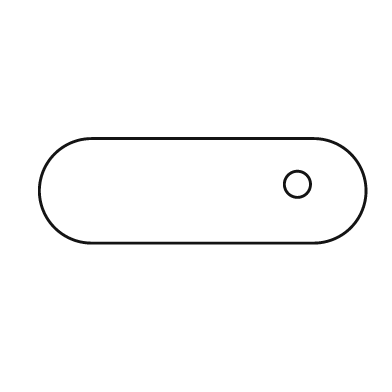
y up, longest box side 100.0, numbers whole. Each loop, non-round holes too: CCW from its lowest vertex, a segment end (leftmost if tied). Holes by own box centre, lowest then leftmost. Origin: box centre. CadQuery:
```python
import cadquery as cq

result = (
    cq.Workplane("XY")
    .moveTo(-34.0, -16.0)
    .lineTo(34.0, -16.0)
    .threePointArc((50.0, 0.0), (34.0, 16.0))
    .lineTo(-34.0, 16.0)
    .threePointArc((-50.0, 0.0), (-34.0, -16.0))
    .close()
    .moveTo(29.0, 2.0)
    .circle(4.0)
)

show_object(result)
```